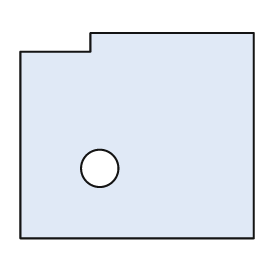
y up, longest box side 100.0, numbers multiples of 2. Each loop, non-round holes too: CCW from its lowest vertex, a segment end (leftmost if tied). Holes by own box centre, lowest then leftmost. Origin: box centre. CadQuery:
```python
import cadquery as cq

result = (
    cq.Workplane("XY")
    .moveTo(-50.0, -44.0)
    .lineTo(50.0, -44.0)
    .lineTo(50.0, 44.0)
    .lineTo(-20.0, 44.0)
    .lineTo(-20.0, 36.0)
    .lineTo(-50.0, 36.0)
    .close()
    .moveTo(-16.0, -14.0)
    .circle(8.0)
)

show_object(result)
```